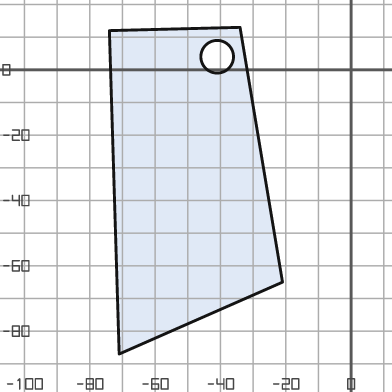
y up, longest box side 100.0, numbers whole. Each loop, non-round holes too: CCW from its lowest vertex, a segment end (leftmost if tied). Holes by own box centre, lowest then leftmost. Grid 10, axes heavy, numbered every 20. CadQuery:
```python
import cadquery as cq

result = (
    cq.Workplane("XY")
    .moveTo(-71.0, -87.0)
    .lineTo(-21.0, -65.0)
    .lineTo(-34.0, 13.0)
    .lineTo(-74.0, 12.0)
    .close()
    .moveTo(-41.0, 4.0)
    .circle(5.0)
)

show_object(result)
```